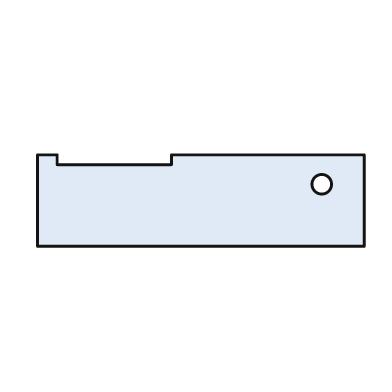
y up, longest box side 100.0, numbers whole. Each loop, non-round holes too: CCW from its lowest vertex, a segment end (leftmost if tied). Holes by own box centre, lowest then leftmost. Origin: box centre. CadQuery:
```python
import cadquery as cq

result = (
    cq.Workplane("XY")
    .moveTo(-50.0, -14.0)
    .lineTo(50.0, -14.0)
    .lineTo(50.0, 14.0)
    .lineTo(-9.0, 14.0)
    .lineTo(-9.0, 11.0)
    .lineTo(-44.0, 11.0)
    .lineTo(-44.0, 14.0)
    .lineTo(-50.0, 14.0)
    .close()
    .moveTo(37.0, 5.0)
    .circle(3.0)
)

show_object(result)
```